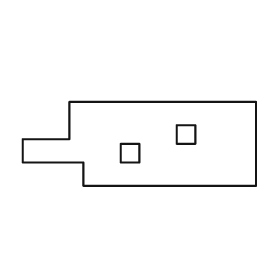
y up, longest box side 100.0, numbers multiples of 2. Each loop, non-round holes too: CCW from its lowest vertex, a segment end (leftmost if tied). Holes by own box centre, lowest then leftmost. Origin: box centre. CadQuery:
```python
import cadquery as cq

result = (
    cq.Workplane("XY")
    .moveTo(-24.0, -18.0)
    .lineTo(50.0, -18.0)
    .lineTo(50.0, 18.0)
    .lineTo(-30.0, 18.0)
    .lineTo(-30.0, 2.0)
    .lineTo(-50.0, 2.0)
    .lineTo(-50.0, -8.0)
    .lineTo(-24.0, -8.0)
    .close()
    .moveTo(-8.0, -8.0)
    .lineTo(0.0, -8.0)
    .lineTo(0.0, 0.0)
    .lineTo(-8.0, 0.0)
    .close()
    .moveTo(16.0, 0.0)
    .lineTo(24.0, 0.0)
    .lineTo(24.0, 8.0)
    .lineTo(16.0, 8.0)
    .close()
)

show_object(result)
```